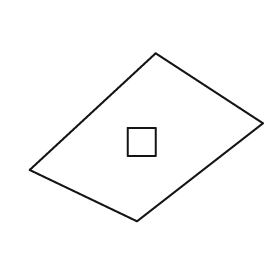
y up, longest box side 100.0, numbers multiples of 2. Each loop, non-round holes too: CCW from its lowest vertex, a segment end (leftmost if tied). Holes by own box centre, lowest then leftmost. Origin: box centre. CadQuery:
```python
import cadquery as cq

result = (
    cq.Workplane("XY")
    .moveTo(-4.0, -36.0)
    .lineTo(50.0, 6.0)
    .lineTo(4.0, 36.0)
    .lineTo(-50.0, -14.0)
    .close()
    .moveTo(-8.0, -8.0)
    .lineTo(4.0, -8.0)
    .lineTo(4.0, 4.0)
    .lineTo(-8.0, 4.0)
    .close()
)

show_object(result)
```